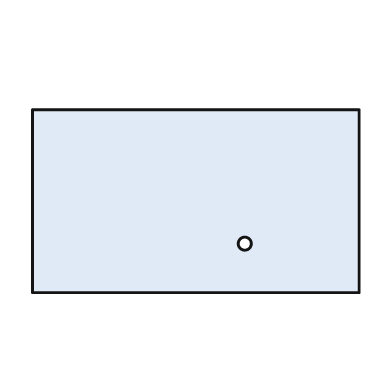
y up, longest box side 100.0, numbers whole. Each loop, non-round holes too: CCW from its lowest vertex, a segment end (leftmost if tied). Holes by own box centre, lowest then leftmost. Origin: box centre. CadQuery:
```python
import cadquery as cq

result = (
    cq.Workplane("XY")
    .moveTo(-50.0, -28.0)
    .lineTo(50.0, -28.0)
    .lineTo(50.0, 28.0)
    .lineTo(-50.0, 28.0)
    .close()
    .moveTo(15.0, -13.0)
    .circle(2.0)
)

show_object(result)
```